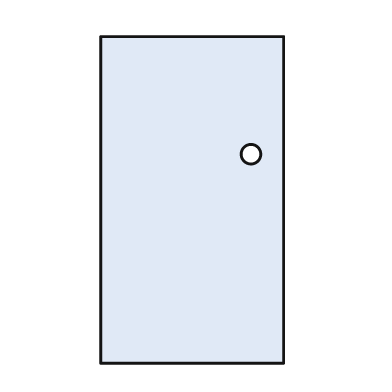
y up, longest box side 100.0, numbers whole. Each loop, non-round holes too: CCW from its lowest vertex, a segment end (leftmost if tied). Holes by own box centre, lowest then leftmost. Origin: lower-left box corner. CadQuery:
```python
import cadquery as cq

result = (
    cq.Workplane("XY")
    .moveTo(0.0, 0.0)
    .lineTo(56.0, 0.0)
    .lineTo(56.0, 100.0)
    .lineTo(0.0, 100.0)
    .close()
    .moveTo(46.0, 64.0)
    .circle(3.0)
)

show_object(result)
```